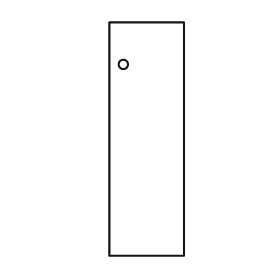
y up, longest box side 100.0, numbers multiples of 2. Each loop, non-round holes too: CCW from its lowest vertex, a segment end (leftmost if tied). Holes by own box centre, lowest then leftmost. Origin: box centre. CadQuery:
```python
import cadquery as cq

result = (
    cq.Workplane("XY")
    .moveTo(-16.0, -50.0)
    .lineTo(16.0, -50.0)
    .lineTo(16.0, 50.0)
    .lineTo(-16.0, 50.0)
    .close()
    .moveTo(-10.0, 32.0)
    .circle(2.0)
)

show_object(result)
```